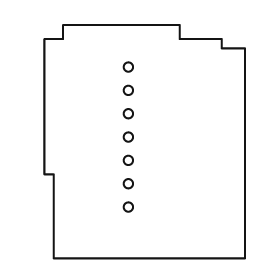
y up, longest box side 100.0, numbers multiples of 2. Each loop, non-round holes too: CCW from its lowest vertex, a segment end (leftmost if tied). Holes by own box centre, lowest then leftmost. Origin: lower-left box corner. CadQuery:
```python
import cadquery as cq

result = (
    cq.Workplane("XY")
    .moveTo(4.0, 0.0)
    .lineTo(86.0, 0.0)
    .lineTo(86.0, 90.0)
    .lineTo(76.0, 90.0)
    .lineTo(76.0, 94.0)
    .lineTo(58.0, 94.0)
    .lineTo(58.0, 100.0)
    .lineTo(8.0, 100.0)
    .lineTo(8.0, 94.0)
    .lineTo(0.0, 94.0)
    .lineTo(0.0, 36.0)
    .lineTo(4.0, 36.0)
    .close()
    .moveTo(36.0, 22.0)
    .circle(2.0)
    .moveTo(36.0, 32.0)
    .circle(2.0)
    .moveTo(36.0, 42.0)
    .circle(2.0)
    .moveTo(36.0, 52.0)
    .circle(2.0)
    .moveTo(36.0, 62.0)
    .circle(2.0)
    .moveTo(36.0, 72.0)
    .circle(2.0)
    .moveTo(36.0, 82.0)
    .circle(2.0)
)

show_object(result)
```